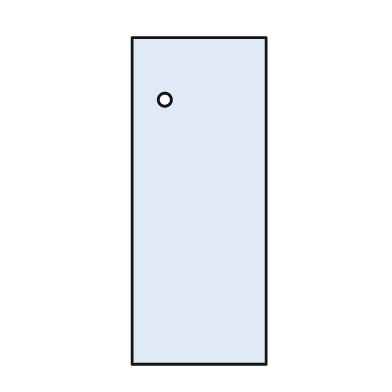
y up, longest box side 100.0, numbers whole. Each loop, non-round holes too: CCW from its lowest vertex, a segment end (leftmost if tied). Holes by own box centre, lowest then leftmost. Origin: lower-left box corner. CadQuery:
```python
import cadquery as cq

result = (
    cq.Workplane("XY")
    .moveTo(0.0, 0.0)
    .lineTo(41.0, 0.0)
    .lineTo(41.0, 100.0)
    .lineTo(0.0, 100.0)
    .close()
    .moveTo(10.0, 81.0)
    .circle(2.0)
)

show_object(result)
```